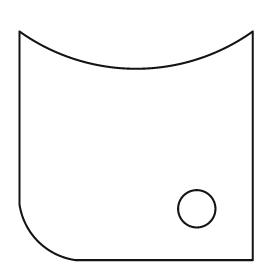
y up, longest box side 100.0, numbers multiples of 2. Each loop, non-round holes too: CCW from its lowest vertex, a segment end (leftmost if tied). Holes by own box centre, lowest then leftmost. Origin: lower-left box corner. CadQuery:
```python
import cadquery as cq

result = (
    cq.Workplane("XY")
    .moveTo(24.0, 0.0)
    .lineTo(100.0, 0.0)
    .lineTo(100.0, 98.0)
    .threePointArc((50.0, 82.0), (0.0, 98.0))
    .lineTo(0.0, 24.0)
    .threePointArc((8.0, 8.0), (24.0, 0.0))
    .close()
    .moveTo(76.0, 22.0)
    .circle(8.0)
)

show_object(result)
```